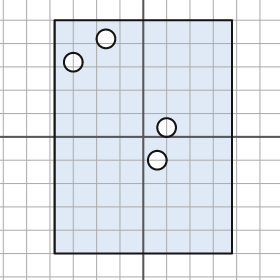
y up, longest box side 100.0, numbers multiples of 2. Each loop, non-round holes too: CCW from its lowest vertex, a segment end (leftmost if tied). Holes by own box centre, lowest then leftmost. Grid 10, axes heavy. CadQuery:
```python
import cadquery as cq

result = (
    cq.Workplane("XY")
    .moveTo(-38.0, -50.0)
    .lineTo(38.0, -50.0)
    .lineTo(38.0, 50.0)
    .lineTo(-38.0, 50.0)
    .close()
    .moveTo(6.0, -10.0)
    .circle(4.0)
    .moveTo(10.0, 4.0)
    .circle(4.0)
    .moveTo(-30.0, 32.0)
    .circle(4.0)
    .moveTo(-16.0, 42.0)
    .circle(4.0)
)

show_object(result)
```